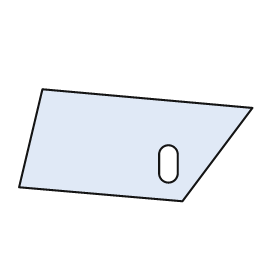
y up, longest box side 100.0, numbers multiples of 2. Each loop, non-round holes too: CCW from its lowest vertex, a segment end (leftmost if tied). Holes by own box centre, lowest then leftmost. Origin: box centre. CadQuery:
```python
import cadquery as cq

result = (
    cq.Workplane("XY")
    .moveTo(20.0, -24.0)
    .lineTo(50.0, 16.0)
    .lineTo(-40.0, 24.0)
    .lineTo(-50.0, -18.0)
    .close()
    .moveTo(10.0, -12.0)
    .threePointArc((14.0, -16.0), (18.0, -12.0))
    .lineTo(18.0, -4.0)
    .threePointArc((14.0, 0.0), (10.0, -4.0))
    .close()
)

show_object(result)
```